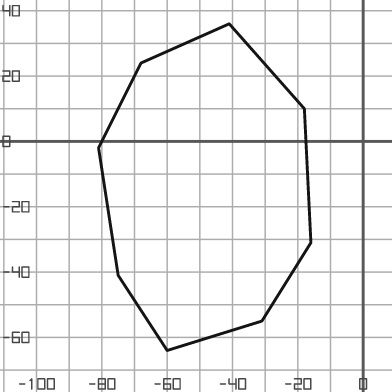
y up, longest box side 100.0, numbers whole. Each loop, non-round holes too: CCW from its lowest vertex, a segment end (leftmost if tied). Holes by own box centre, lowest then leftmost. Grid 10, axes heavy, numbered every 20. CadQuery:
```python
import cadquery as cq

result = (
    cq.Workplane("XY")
    .moveTo(-60.0, -64.0)
    .lineTo(-31.0, -55.0)
    .lineTo(-16.0, -31.0)
    .lineTo(-18.0, 10.0)
    .lineTo(-41.0, 36.0)
    .lineTo(-68.0, 24.0)
    .lineTo(-81.0, -2.0)
    .lineTo(-75.0, -41.0)
    .close()
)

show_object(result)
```